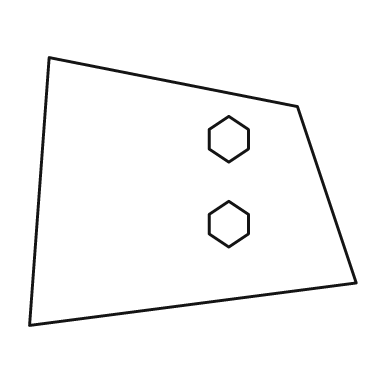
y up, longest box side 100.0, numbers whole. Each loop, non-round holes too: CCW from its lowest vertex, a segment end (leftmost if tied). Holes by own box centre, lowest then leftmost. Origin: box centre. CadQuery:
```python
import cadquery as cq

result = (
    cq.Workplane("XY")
    .moveTo(-50.0, -41.0)
    .lineTo(50.0, -28.0)
    .lineTo(32.0, 26.0)
    .lineTo(-44.0, 41.0)
    .close()
    .moveTo(11.0, -17.0)
    .lineTo(17.0, -13.0)
    .lineTo(17.0, -7.0)
    .lineTo(11.0, -3.0)
    .lineTo(5.0, -7.0)
    .lineTo(5.0, -13.0)
    .close()
    .moveTo(11.0, 9.0)
    .lineTo(17.0, 13.0)
    .lineTo(17.0, 19.0)
    .lineTo(11.0, 23.0)
    .lineTo(5.0, 19.0)
    .lineTo(5.0, 13.0)
    .close()
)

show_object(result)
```